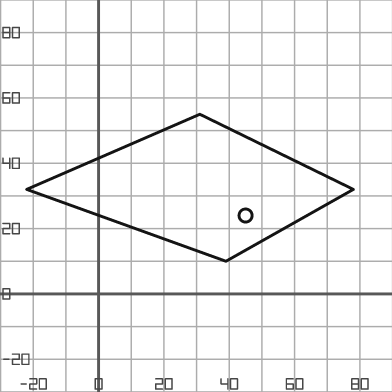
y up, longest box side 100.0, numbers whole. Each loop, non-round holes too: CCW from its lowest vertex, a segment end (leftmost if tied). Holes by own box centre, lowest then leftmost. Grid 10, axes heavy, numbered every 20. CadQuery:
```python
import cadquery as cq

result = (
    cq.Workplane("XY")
    .moveTo(39.0, 10.0)
    .lineTo(78.0, 32.0)
    .lineTo(31.0, 55.0)
    .lineTo(-22.0, 32.0)
    .close()
    .moveTo(45.0, 24.0)
    .circle(2.0)
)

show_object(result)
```